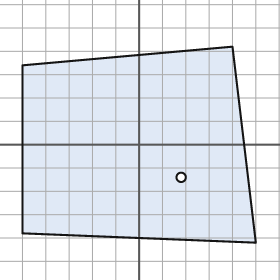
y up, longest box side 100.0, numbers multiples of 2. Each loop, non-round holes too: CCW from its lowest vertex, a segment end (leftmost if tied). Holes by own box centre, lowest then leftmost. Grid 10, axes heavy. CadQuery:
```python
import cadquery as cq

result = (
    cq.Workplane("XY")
    .moveTo(50.0, -42.0)
    .lineTo(40.0, 42.0)
    .lineTo(-50.0, 34.0)
    .lineTo(-50.0, -38.0)
    .close()
    .moveTo(18.0, -14.0)
    .circle(2.0)
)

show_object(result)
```